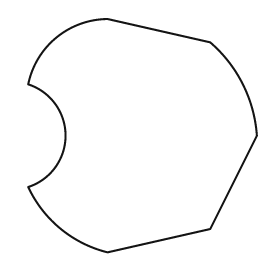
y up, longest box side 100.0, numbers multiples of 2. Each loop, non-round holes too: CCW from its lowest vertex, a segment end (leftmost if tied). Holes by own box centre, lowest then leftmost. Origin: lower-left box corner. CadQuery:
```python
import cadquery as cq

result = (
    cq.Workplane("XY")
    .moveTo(34.0, 0.0)
    .lineTo(78.0, 10.0)
    .lineTo(98.0, 50.0)
    .threePointArc((92.0, 72.0), (78.0, 90.0))
    .lineTo(34.0, 100.0)
    .threePointArc((12.0, 92.0), (0.0, 72.0))
    .threePointArc((16.0, 50.0), (0.0, 28.0))
    .threePointArc((14.0, 10.0), (34.0, 0.0))
    .close()
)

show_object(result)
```